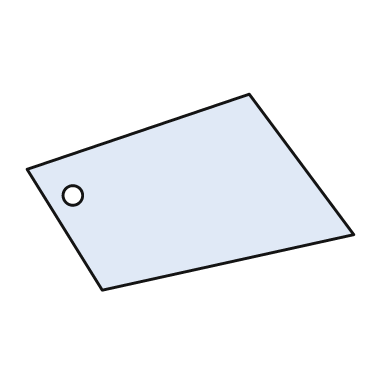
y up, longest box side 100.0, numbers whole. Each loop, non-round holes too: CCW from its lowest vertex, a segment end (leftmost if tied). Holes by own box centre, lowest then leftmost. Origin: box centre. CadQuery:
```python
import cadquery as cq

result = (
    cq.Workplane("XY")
    .moveTo(-27.0, -30.0)
    .lineTo(50.0, -13.0)
    .lineTo(18.0, 30.0)
    .lineTo(-50.0, 7.0)
    .close()
    .moveTo(-36.0, -1.0)
    .circle(3.0)
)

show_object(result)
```